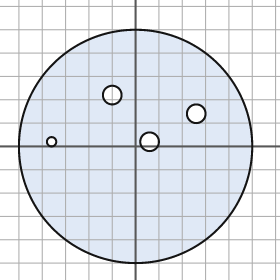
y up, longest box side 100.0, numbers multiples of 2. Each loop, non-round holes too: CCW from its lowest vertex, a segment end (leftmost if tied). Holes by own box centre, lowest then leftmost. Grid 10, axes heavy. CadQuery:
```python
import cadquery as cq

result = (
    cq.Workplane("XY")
    .moveTo(0.0, 0.0)
    .circle(50.0)
    .moveTo(-36.0, 2.0)
    .circle(2.0)
    .moveTo(6.0, 2.0)
    .circle(4.0)
    .moveTo(26.0, 14.0)
    .circle(4.0)
    .moveTo(-10.0, 22.0)
    .circle(4.0)
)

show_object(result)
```